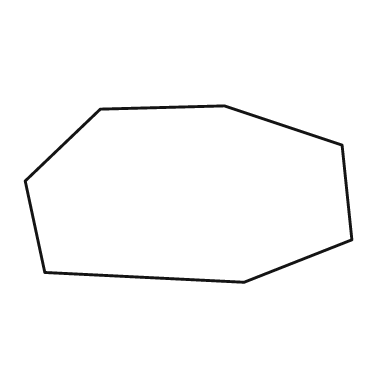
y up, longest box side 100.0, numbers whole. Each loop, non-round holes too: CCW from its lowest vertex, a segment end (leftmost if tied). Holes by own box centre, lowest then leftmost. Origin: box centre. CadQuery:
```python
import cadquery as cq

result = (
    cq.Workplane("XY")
    .moveTo(17.0, -27.0)
    .lineTo(50.0, -14.0)
    .lineTo(47.0, 15.0)
    .lineTo(11.0, 27.0)
    .lineTo(-27.0, 26.0)
    .lineTo(-50.0, 4.0)
    .lineTo(-44.0, -24.0)
    .close()
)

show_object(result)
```